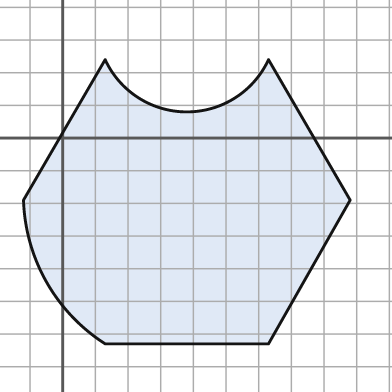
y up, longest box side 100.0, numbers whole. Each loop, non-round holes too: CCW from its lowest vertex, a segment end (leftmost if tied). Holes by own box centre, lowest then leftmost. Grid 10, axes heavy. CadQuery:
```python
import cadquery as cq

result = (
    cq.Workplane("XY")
    .moveTo(13.0, -63.0)
    .lineTo(63.0, -63.0)
    .lineTo(88.0, -19.0)
    .lineTo(63.0, 24.0)
    .threePointArc((38.0, 8.0), (13.0, 24.0))
    .lineTo(-12.0, -19.0)
    .threePointArc((-5.0, -44.0), (13.0, -63.0))
    .close()
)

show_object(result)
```